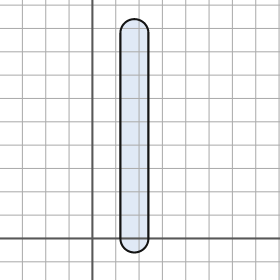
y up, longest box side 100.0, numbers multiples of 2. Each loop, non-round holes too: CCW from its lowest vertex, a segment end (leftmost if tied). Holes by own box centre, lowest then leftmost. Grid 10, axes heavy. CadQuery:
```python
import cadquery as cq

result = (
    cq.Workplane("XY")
    .moveTo(12.0, 0.0)
    .threePointArc((18.0, -6.0), (24.0, 0.0))
    .lineTo(24.0, 88.0)
    .threePointArc((18.0, 94.0), (12.0, 88.0))
    .close()
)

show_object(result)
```